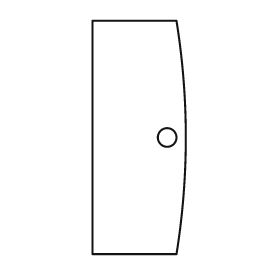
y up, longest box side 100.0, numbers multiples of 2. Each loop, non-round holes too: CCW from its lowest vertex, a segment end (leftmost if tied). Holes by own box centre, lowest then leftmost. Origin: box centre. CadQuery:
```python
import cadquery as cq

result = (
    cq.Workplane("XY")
    .moveTo(-20.0, -50.0)
    .lineTo(16.0, -50.0)
    .threePointArc((20.0, 0.0), (16.0, 50.0))
    .lineTo(-20.0, 50.0)
    .close()
    .moveTo(12.0, 0.0)
    .circle(4.0)
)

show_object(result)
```